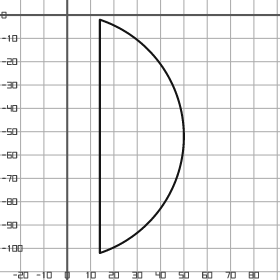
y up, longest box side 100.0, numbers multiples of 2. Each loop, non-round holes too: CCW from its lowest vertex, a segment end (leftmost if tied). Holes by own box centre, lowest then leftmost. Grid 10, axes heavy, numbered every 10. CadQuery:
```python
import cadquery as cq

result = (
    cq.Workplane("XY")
    .moveTo(14.0, -102.0)
    .threePointArc((50.0, -52.0), (14.0, -2.0))
    .close()
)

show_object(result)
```